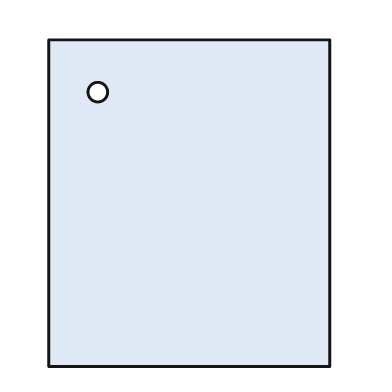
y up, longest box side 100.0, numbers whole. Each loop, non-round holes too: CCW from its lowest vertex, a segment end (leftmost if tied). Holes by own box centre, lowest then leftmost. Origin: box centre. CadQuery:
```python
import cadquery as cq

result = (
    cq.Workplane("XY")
    .moveTo(-43.0, -50.0)
    .lineTo(43.0, -50.0)
    .lineTo(43.0, 50.0)
    .lineTo(-43.0, 50.0)
    .close()
    .moveTo(-28.0, 34.0)
    .circle(3.0)
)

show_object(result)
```